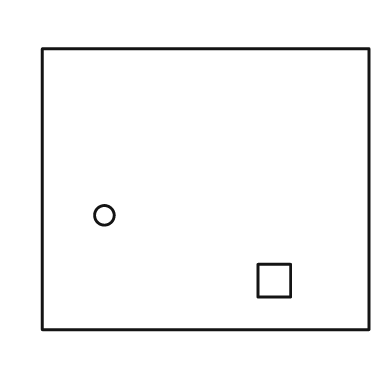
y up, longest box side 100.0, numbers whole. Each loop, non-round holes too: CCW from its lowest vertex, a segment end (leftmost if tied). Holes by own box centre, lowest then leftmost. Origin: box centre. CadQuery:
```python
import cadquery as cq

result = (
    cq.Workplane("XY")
    .moveTo(-50.0, -43.0)
    .lineTo(50.0, -43.0)
    .lineTo(50.0, 43.0)
    .lineTo(-50.0, 43.0)
    .close()
    .moveTo(16.0, -33.0)
    .lineTo(26.0, -33.0)
    .lineTo(26.0, -23.0)
    .lineTo(16.0, -23.0)
    .close()
    .moveTo(-31.0, -8.0)
    .circle(3.0)
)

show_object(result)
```